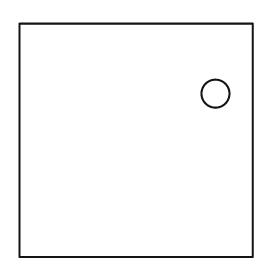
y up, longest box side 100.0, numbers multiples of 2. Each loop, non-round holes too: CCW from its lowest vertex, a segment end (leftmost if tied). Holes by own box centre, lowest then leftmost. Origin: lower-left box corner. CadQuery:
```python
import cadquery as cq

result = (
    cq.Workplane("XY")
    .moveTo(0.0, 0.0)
    .lineTo(100.0, 0.0)
    .lineTo(100.0, 100.0)
    .lineTo(0.0, 100.0)
    .close()
    .moveTo(84.0, 70.0)
    .circle(6.0)
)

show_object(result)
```